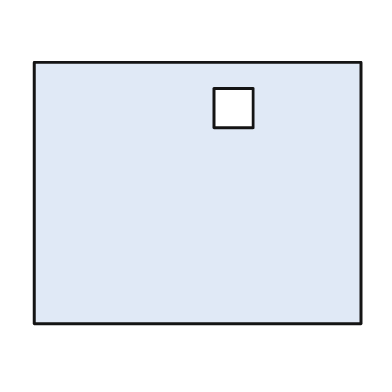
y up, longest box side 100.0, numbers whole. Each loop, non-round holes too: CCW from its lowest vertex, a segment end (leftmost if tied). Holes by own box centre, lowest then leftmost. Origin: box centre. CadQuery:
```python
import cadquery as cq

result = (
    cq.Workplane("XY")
    .moveTo(-50.0, -40.0)
    .lineTo(50.0, -40.0)
    .lineTo(50.0, 40.0)
    .lineTo(-50.0, 40.0)
    .close()
    .moveTo(5.0, 20.0)
    .lineTo(17.0, 20.0)
    .lineTo(17.0, 32.0)
    .lineTo(5.0, 32.0)
    .close()
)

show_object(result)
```